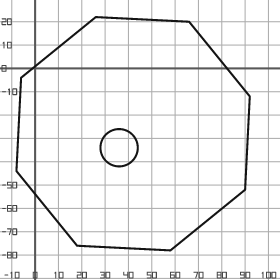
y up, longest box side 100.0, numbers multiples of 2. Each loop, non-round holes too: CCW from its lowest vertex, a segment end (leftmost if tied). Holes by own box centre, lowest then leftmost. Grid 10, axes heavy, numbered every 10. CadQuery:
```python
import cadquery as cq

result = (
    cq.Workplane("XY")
    .moveTo(58.0, -78.0)
    .lineTo(90.0, -52.0)
    .lineTo(92.0, -12.0)
    .lineTo(66.0, 20.0)
    .lineTo(26.0, 22.0)
    .lineTo(-6.0, -4.0)
    .lineTo(-8.0, -44.0)
    .lineTo(18.0, -76.0)
    .close()
    .moveTo(36.0, -34.0)
    .circle(8.0)
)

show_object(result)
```